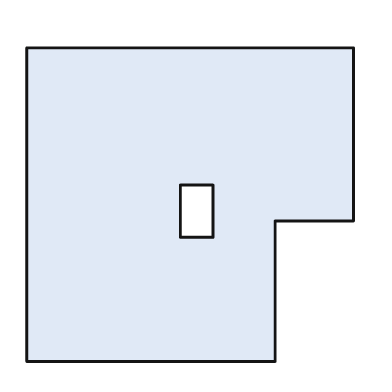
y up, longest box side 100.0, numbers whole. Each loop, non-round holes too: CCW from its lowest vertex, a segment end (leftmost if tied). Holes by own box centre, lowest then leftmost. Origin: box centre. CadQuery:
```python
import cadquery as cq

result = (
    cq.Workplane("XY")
    .moveTo(-50.0, -48.0)
    .lineTo(26.0, -48.0)
    .lineTo(26.0, -5.0)
    .lineTo(50.0, -5.0)
    .lineTo(50.0, 48.0)
    .lineTo(-50.0, 48.0)
    .close()
    .moveTo(-3.0, -10.0)
    .lineTo(7.0, -10.0)
    .lineTo(7.0, 6.0)
    .lineTo(-3.0, 6.0)
    .close()
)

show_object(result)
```